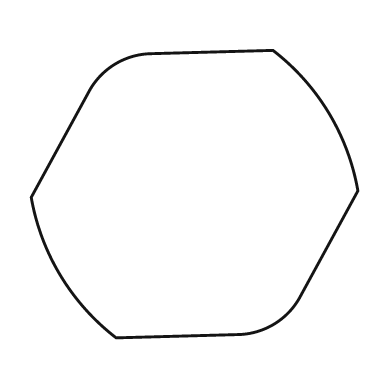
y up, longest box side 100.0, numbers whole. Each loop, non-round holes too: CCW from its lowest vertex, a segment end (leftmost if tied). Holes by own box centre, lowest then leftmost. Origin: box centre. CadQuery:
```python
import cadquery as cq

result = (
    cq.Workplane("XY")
    .moveTo(-24.0, -44.0)
    .lineTo(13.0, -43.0)
    .threePointArc((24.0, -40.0), (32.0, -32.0))
    .lineTo(50.0, 1.0)
    .threePointArc((41.0, 25.0), (24.0, 44.0))
    .lineTo(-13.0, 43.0)
    .threePointArc((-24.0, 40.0), (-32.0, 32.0))
    .lineTo(-50.0, -1.0)
    .threePointArc((-41.0, -25.0), (-24.0, -44.0))
    .close()
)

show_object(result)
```